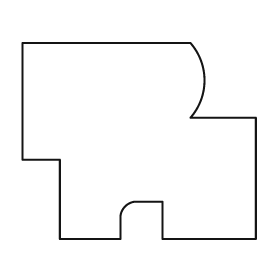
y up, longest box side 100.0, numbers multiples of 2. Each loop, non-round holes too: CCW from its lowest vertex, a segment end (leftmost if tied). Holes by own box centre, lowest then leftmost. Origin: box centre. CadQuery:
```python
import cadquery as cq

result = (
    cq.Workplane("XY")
    .moveTo(-34.0, -42.0)
    .lineTo(-8.0, -42.0)
    .lineTo(-8.0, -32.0)
    .threePointArc((-6.0, -28.0), (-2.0, -26.0))
    .lineTo(10.0, -26.0)
    .lineTo(10.0, -42.0)
    .lineTo(50.0, -42.0)
    .lineTo(50.0, 10.0)
    .lineTo(22.0, 10.0)
    .threePointArc((28.0, 26.0), (22.0, 42.0))
    .lineTo(-50.0, 42.0)
    .lineTo(-50.0, -8.0)
    .lineTo(-34.0, -8.0)
    .close()
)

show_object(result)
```